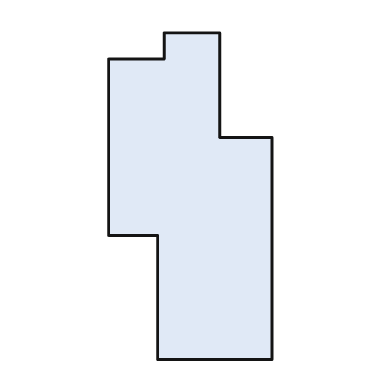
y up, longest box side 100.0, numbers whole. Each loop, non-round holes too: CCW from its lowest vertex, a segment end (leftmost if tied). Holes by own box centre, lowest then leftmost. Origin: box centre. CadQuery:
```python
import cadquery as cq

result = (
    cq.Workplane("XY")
    .moveTo(-10.0, -50.0)
    .lineTo(25.0, -50.0)
    .lineTo(25.0, 18.0)
    .lineTo(9.0, 18.0)
    .lineTo(9.0, 50.0)
    .lineTo(-8.0, 50.0)
    .lineTo(-8.0, 42.0)
    .lineTo(-25.0, 42.0)
    .lineTo(-25.0, -12.0)
    .lineTo(-10.0, -12.0)
    .close()
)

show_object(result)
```